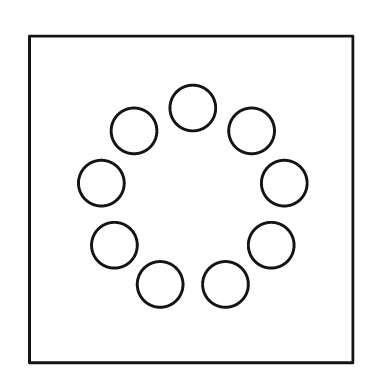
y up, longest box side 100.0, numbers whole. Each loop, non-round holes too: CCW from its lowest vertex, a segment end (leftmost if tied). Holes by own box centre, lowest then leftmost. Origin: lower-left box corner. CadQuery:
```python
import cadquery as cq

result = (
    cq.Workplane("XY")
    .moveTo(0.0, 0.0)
    .lineTo(99.0, 0.0)
    .lineTo(99.0, 100.0)
    .lineTo(0.0, 100.0)
    .close()
    .moveTo(40.0, 24.0)
    .circle(7.0)
    .moveTo(60.0, 24.0)
    .circle(7.0)
    .moveTo(26.0, 36.0)
    .circle(7.0)
    .moveTo(74.0, 36.0)
    .circle(7.0)
    .moveTo(22.0, 55.0)
    .circle(7.0)
    .moveTo(78.0, 55.0)
    .circle(7.0)
    .moveTo(32.0, 71.0)
    .circle(7.0)
    .moveTo(68.0, 71.0)
    .circle(7.0)
    .moveTo(50.0, 78.0)
    .circle(7.0)
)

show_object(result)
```